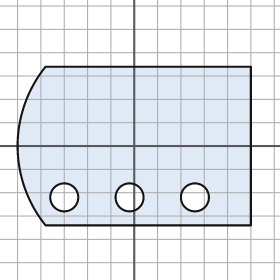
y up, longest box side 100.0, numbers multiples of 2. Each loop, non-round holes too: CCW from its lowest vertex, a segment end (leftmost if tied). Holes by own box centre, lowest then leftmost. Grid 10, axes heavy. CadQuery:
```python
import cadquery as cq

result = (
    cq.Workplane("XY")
    .moveTo(-38.0, -34.0)
    .lineTo(50.0, -34.0)
    .lineTo(50.0, 34.0)
    .lineTo(-38.0, 34.0)
    .threePointArc((-50.0, 0.0), (-38.0, -34.0))
    .close()
    .moveTo(-30.0, -22.0)
    .circle(6.0)
    .moveTo(-2.0, -22.0)
    .circle(6.0)
    .moveTo(26.0, -22.0)
    .circle(6.0)
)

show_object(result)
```